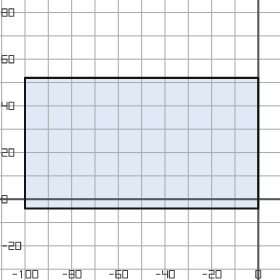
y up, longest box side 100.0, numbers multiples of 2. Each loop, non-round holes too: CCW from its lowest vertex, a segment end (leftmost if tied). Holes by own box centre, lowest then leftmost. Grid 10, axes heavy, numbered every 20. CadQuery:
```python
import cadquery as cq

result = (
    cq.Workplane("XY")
    .moveTo(-100.0, -4.0)
    .lineTo(0.0, -4.0)
    .lineTo(0.0, 52.0)
    .lineTo(-100.0, 52.0)
    .close()
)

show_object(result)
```